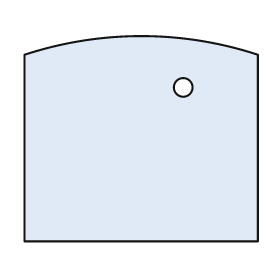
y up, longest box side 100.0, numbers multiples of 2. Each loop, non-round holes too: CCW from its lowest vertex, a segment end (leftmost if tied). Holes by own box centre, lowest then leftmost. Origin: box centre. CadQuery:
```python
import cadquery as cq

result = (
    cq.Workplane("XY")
    .moveTo(-50.0, -44.0)
    .lineTo(50.0, -44.0)
    .lineTo(50.0, 36.0)
    .threePointArc((0.0, 44.0), (-50.0, 36.0))
    .close()
    .moveTo(18.0, 22.0)
    .circle(4.0)
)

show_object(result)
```